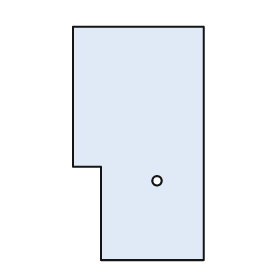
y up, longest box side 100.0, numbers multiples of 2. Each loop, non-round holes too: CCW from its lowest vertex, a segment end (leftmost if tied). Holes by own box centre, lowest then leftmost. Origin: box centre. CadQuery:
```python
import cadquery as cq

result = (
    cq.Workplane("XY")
    .moveTo(-16.0, -50.0)
    .lineTo(28.0, -50.0)
    .lineTo(28.0, 50.0)
    .lineTo(-28.0, 50.0)
    .lineTo(-28.0, -10.0)
    .lineTo(-16.0, -10.0)
    .close()
    .moveTo(8.0, -16.0)
    .circle(2.0)
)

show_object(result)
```